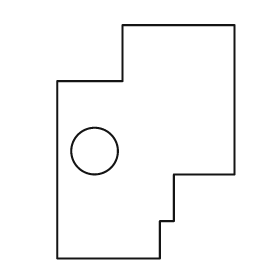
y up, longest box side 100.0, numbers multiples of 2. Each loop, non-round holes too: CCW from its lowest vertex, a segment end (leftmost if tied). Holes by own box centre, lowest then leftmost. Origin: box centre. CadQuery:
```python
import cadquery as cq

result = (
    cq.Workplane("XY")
    .moveTo(-38.0, -50.0)
    .lineTo(6.0, -50.0)
    .lineTo(6.0, -34.0)
    .lineTo(12.0, -34.0)
    .lineTo(12.0, -14.0)
    .lineTo(38.0, -14.0)
    .lineTo(38.0, 50.0)
    .lineTo(-10.0, 50.0)
    .lineTo(-10.0, 26.0)
    .lineTo(-38.0, 26.0)
    .close()
    .moveTo(-22.0, -4.0)
    .circle(10.0)
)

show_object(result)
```